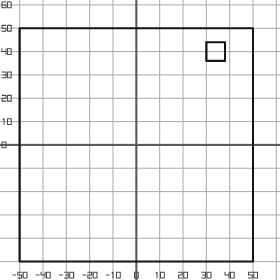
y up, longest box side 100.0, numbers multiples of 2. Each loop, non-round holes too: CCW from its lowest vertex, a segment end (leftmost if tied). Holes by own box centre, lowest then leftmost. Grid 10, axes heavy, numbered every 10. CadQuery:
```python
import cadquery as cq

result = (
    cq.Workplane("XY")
    .moveTo(-50.0, -50.0)
    .lineTo(50.0, -50.0)
    .lineTo(50.0, 50.0)
    .lineTo(-50.0, 50.0)
    .close()
    .moveTo(30.0, 36.0)
    .lineTo(38.0, 36.0)
    .lineTo(38.0, 44.0)
    .lineTo(30.0, 44.0)
    .close()
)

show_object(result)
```